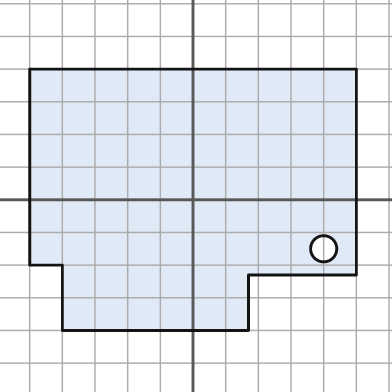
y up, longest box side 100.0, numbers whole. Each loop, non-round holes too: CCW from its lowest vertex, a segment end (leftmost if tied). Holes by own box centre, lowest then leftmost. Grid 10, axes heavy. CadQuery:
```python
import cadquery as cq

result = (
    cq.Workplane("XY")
    .moveTo(-40.0, -40.0)
    .lineTo(17.0, -40.0)
    .lineTo(17.0, -23.0)
    .lineTo(50.0, -23.0)
    .lineTo(50.0, 40.0)
    .lineTo(-50.0, 40.0)
    .lineTo(-50.0, -20.0)
    .lineTo(-40.0, -20.0)
    .close()
    .moveTo(40.0, -15.0)
    .circle(4.0)
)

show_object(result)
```